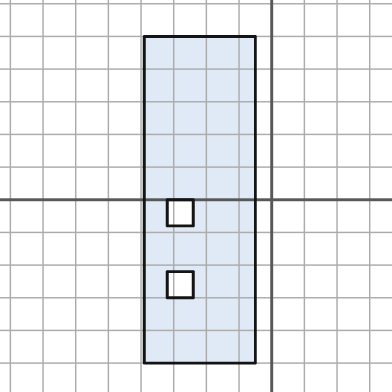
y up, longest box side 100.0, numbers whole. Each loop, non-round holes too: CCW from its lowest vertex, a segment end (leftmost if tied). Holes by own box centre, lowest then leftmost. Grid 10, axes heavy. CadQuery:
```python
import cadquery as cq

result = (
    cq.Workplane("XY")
    .moveTo(-39.0, -50.0)
    .lineTo(-5.0, -50.0)
    .lineTo(-5.0, 50.0)
    .lineTo(-39.0, 50.0)
    .close()
    .moveTo(-32.0, -30.0)
    .lineTo(-24.0, -30.0)
    .lineTo(-24.0, -22.0)
    .lineTo(-32.0, -22.0)
    .close()
    .moveTo(-32.0, -8.0)
    .lineTo(-24.0, -8.0)
    .lineTo(-24.0, 0.0)
    .lineTo(-32.0, 0.0)
    .close()
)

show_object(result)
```